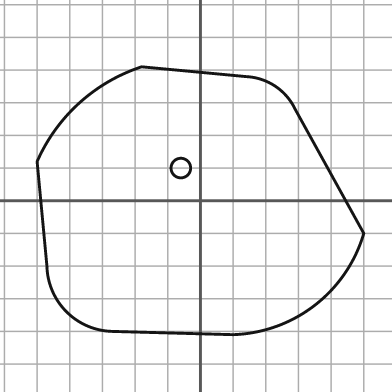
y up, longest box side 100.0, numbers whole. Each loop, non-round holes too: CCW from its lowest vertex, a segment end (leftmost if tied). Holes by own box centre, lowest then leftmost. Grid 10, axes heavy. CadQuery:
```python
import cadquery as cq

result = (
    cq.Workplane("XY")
    .moveTo(10.0, -41.0)
    .threePointArc((35.0, -32.0), (50.0, -10.0))
    .lineTo(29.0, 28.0)
    .threePointArc((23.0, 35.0), (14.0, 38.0))
    .lineTo(-18.0, 41.0)
    .threePointArc((-37.0, 30.0), (-50.0, 12.0))
    .lineTo(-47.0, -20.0)
    .threePointArc((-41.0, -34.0), (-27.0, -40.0))
    .close()
    .moveTo(-6.0, 10.0)
    .circle(3.0)
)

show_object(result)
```